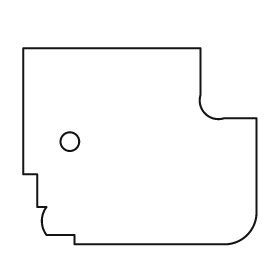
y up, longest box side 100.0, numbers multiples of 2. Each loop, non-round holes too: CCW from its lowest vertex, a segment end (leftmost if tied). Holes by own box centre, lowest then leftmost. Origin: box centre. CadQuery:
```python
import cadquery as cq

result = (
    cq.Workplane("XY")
    .moveTo(-28.0, -42.0)
    .lineTo(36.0, -42.0)
    .threePointArc((46.0, -38.0), (50.0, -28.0))
    .lineTo(50.0, 12.0)
    .lineTo(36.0, 12.0)
    .threePointArc((28.0, 14.0), (26.0, 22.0))
    .lineTo(26.0, 42.0)
    .lineTo(-50.0, 42.0)
    .lineTo(-50.0, -12.0)
    .lineTo(-44.0, -12.0)
    .lineTo(-44.0, -26.0)
    .lineTo(-40.0, -26.0)
    .threePointArc((-42.0, -32.0), (-40.0, -38.0))
    .lineTo(-28.0, -38.0)
    .close()
    .moveTo(-30.0, 2.0)
    .circle(4.0)
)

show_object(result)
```